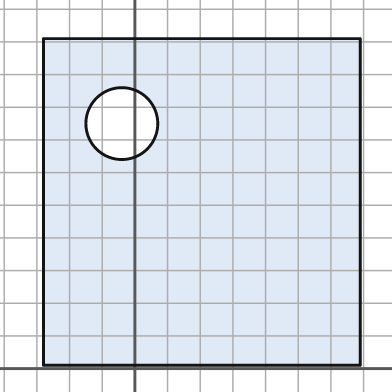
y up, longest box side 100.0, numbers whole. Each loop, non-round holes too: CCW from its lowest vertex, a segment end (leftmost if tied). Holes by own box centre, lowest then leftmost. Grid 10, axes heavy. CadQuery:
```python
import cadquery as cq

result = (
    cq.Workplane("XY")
    .moveTo(-28.0, 1.0)
    .lineTo(69.0, 1.0)
    .lineTo(69.0, 101.0)
    .lineTo(-28.0, 101.0)
    .close()
    .moveTo(-4.0, 75.0)
    .circle(11.0)
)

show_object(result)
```